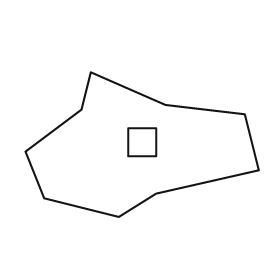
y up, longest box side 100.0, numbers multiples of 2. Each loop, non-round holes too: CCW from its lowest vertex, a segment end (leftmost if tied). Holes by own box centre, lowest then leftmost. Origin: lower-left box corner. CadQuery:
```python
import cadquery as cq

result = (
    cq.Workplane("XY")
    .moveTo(40.0, 0.0)
    .lineTo(56.0, 10.0)
    .lineTo(100.0, 20.0)
    .lineTo(94.0, 44.0)
    .lineTo(60.0, 48.0)
    .lineTo(28.0, 62.0)
    .lineTo(24.0, 46.0)
    .lineTo(0.0, 28.0)
    .lineTo(8.0, 8.0)
    .close()
    .moveTo(44.0, 26.0)
    .lineTo(56.0, 26.0)
    .lineTo(56.0, 38.0)
    .lineTo(44.0, 38.0)
    .close()
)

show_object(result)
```